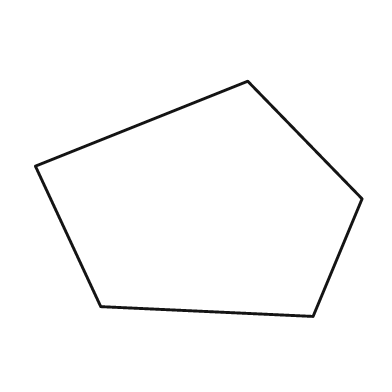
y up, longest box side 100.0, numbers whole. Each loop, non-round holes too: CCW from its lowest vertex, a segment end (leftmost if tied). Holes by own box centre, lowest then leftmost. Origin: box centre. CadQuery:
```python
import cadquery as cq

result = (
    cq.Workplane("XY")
    .moveTo(35.0, -36.0)
    .lineTo(50.0, 0.0)
    .lineTo(15.0, 36.0)
    .lineTo(-50.0, 10.0)
    .lineTo(-30.0, -33.0)
    .close()
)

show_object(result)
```